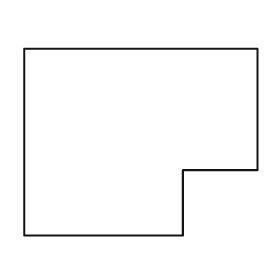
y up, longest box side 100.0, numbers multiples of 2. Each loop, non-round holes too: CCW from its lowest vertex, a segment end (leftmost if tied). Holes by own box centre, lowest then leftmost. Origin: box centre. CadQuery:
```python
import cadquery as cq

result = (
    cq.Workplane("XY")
    .moveTo(-50.0, -40.0)
    .lineTo(18.0, -40.0)
    .lineTo(18.0, -12.0)
    .lineTo(50.0, -12.0)
    .lineTo(50.0, 40.0)
    .lineTo(-50.0, 40.0)
    .close()
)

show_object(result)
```